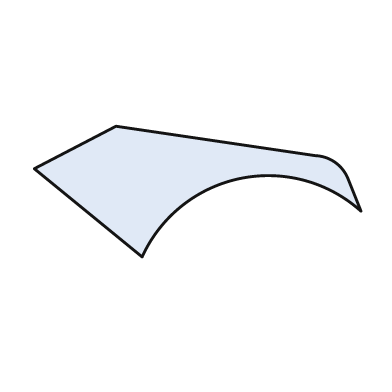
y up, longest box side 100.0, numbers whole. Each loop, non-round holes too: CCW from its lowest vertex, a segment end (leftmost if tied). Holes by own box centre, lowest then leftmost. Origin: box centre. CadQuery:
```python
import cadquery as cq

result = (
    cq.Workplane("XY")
    .moveTo(-17.0, -20.0)
    .threePointArc((13.0, 4.0), (50.0, -6.0))
    .lineTo(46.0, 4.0)
    .threePointArc((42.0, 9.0), (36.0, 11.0))
    .lineTo(-25.0, 20.0)
    .lineTo(-50.0, 7.0)
    .close()
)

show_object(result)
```